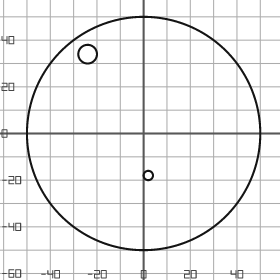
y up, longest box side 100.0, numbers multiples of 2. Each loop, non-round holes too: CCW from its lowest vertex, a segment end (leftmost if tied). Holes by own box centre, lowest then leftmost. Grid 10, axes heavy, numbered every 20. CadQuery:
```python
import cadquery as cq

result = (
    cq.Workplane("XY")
    .moveTo(0.0, 0.0)
    .circle(50.0)
    .moveTo(2.0, -18.0)
    .circle(2.0)
    .moveTo(-24.0, 34.0)
    .circle(4.0)
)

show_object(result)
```